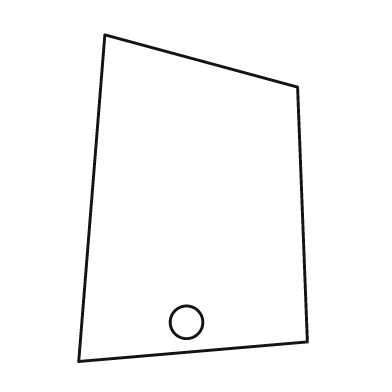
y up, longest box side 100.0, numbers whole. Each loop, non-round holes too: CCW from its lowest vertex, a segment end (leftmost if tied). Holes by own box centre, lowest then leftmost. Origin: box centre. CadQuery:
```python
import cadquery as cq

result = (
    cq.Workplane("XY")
    .moveTo(-35.0, -50.0)
    .lineTo(35.0, -44.0)
    .lineTo(32.0, 34.0)
    .lineTo(-27.0, 50.0)
    .close()
    .moveTo(-2.0, -38.0)
    .circle(5.0)
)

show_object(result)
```